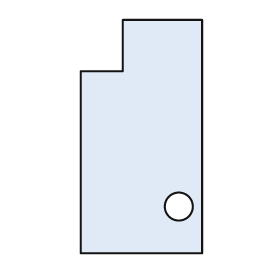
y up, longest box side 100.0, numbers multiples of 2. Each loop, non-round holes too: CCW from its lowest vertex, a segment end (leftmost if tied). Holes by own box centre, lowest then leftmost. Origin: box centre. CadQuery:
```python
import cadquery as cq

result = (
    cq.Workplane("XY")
    .moveTo(-26.0, -50.0)
    .lineTo(26.0, -50.0)
    .lineTo(26.0, 50.0)
    .lineTo(-8.0, 50.0)
    .lineTo(-8.0, 28.0)
    .lineTo(-26.0, 28.0)
    .close()
    .moveTo(16.0, -30.0)
    .circle(6.0)
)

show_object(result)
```